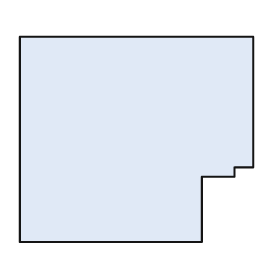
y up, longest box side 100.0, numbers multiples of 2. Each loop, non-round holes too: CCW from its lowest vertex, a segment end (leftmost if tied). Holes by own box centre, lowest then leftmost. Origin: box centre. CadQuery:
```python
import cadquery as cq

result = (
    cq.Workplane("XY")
    .moveTo(-50.0, -44.0)
    .lineTo(28.0, -44.0)
    .lineTo(28.0, -16.0)
    .lineTo(42.0, -16.0)
    .lineTo(42.0, -12.0)
    .lineTo(50.0, -12.0)
    .lineTo(50.0, 44.0)
    .lineTo(-50.0, 44.0)
    .close()
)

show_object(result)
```